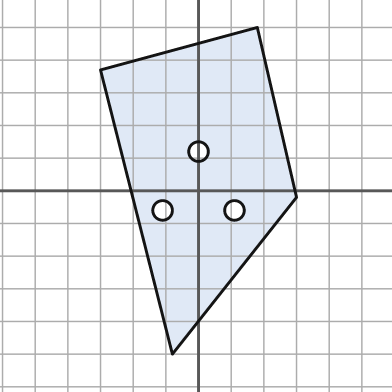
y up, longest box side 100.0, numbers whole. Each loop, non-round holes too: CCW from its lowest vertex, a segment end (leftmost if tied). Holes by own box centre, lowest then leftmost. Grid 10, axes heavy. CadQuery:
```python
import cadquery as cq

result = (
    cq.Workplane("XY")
    .moveTo(-8.0, -50.0)
    .lineTo(30.0, -2.0)
    .lineTo(18.0, 50.0)
    .lineTo(-30.0, 37.0)
    .close()
    .moveTo(-11.0, -6.0)
    .circle(3.0)
    .moveTo(11.0, -6.0)
    .circle(3.0)
    .moveTo(0.0, 12.0)
    .circle(3.0)
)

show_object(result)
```